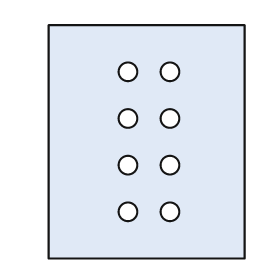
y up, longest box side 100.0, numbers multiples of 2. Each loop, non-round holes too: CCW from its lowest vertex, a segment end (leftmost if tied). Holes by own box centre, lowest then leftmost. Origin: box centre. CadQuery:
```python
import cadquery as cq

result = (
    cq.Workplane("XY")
    .moveTo(-42.0, -50.0)
    .lineTo(42.0, -50.0)
    .lineTo(42.0, 50.0)
    .lineTo(-42.0, 50.0)
    .close()
    .moveTo(-8.0, -30.0)
    .circle(4.0)
    .moveTo(10.0, -30.0)
    .circle(4.0)
    .moveTo(-8.0, -10.0)
    .circle(4.0)
    .moveTo(10.0, -10.0)
    .circle(4.0)
    .moveTo(-8.0, 10.0)
    .circle(4.0)
    .moveTo(10.0, 10.0)
    .circle(4.0)
    .moveTo(-8.0, 30.0)
    .circle(4.0)
    .moveTo(10.0, 30.0)
    .circle(4.0)
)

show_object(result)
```